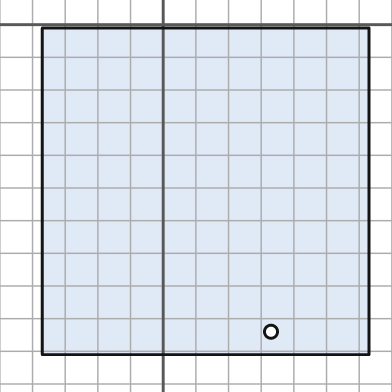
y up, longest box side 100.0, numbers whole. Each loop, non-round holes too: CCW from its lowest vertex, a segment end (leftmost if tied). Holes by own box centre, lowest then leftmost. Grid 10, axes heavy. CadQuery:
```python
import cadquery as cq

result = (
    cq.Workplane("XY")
    .moveTo(-37.0, -101.0)
    .lineTo(63.0, -101.0)
    .lineTo(63.0, -1.0)
    .lineTo(-37.0, -1.0)
    .close()
    .moveTo(33.0, -94.0)
    .circle(2.0)
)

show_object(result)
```